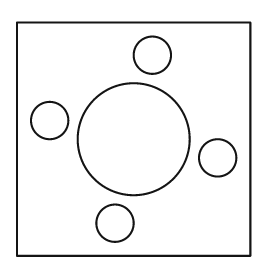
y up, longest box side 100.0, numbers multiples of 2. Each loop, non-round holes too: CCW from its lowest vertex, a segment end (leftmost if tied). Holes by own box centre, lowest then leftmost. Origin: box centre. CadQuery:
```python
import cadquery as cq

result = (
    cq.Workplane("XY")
    .moveTo(-50.0, -50.0)
    .lineTo(50.0, -50.0)
    .lineTo(50.0, 50.0)
    .lineTo(-50.0, 50.0)
    .close()
    .moveTo(-8.0, -36.0)
    .circle(8.0)
    .moveTo(36.0, -8.0)
    .circle(8.0)
    .moveTo(0.0, 0.0)
    .circle(24.0)
    .moveTo(-36.0, 8.0)
    .circle(8.0)
    .moveTo(8.0, 36.0)
    .circle(8.0)
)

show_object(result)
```